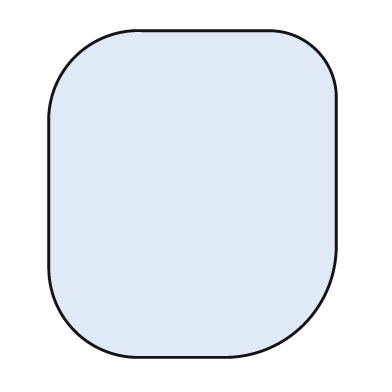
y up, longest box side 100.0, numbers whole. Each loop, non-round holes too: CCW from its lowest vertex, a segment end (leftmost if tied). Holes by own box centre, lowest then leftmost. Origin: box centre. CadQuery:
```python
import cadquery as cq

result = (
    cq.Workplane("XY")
    .moveTo(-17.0, -50.0)
    .lineTo(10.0, -50.0)
    .threePointArc((34.0, -40.0), (44.0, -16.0))
    .lineTo(44.0, 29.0)
    .threePointArc((38.0, 44.0), (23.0, 50.0))
    .lineTo(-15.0, 50.0)
    .threePointArc((-36.0, 42.0), (-44.0, 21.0))
    .lineTo(-44.0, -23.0)
    .threePointArc((-36.0, -42.0), (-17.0, -50.0))
    .close()
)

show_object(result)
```